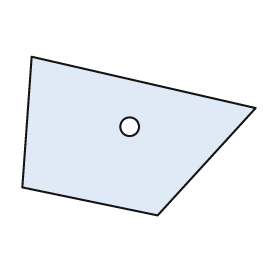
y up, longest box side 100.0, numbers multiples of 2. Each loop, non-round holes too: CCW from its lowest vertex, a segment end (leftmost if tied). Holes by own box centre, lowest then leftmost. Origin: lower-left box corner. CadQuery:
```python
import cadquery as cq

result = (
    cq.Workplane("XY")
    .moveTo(58.0, 0.0)
    .lineTo(100.0, 46.0)
    .lineTo(4.0, 68.0)
    .lineTo(0.0, 12.0)
    .close()
    .moveTo(46.0, 38.0)
    .circle(4.0)
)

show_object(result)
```